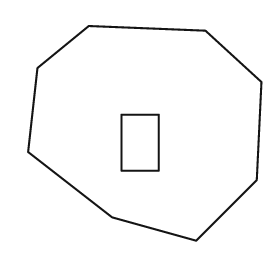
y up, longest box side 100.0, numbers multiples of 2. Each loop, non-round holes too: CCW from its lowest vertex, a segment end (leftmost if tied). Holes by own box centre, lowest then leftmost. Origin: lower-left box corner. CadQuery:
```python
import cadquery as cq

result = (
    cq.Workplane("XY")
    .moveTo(72.0, 0.0)
    .lineTo(98.0, 26.0)
    .lineTo(100.0, 68.0)
    .lineTo(76.0, 90.0)
    .lineTo(26.0, 92.0)
    .lineTo(4.0, 74.0)
    .lineTo(0.0, 38.0)
    .lineTo(36.0, 10.0)
    .close()
    .moveTo(40.0, 30.0)
    .lineTo(56.0, 30.0)
    .lineTo(56.0, 54.0)
    .lineTo(40.0, 54.0)
    .close()
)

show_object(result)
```